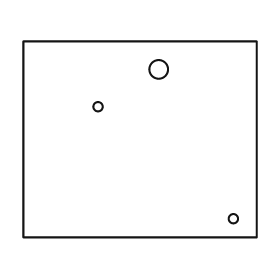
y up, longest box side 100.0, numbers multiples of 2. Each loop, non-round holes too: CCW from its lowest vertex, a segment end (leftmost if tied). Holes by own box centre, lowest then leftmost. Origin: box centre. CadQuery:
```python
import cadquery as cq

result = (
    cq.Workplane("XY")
    .moveTo(-50.0, -42.0)
    .lineTo(50.0, -42.0)
    .lineTo(50.0, 42.0)
    .lineTo(-50.0, 42.0)
    .close()
    .moveTo(40.0, -34.0)
    .circle(2.0)
    .moveTo(-18.0, 14.0)
    .circle(2.0)
    .moveTo(8.0, 30.0)
    .circle(4.0)
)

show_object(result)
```